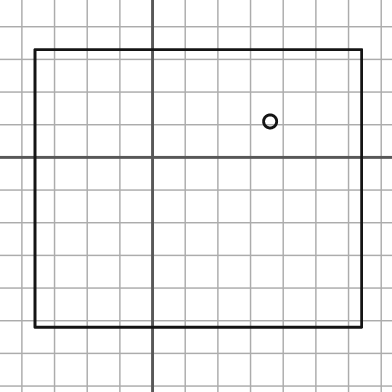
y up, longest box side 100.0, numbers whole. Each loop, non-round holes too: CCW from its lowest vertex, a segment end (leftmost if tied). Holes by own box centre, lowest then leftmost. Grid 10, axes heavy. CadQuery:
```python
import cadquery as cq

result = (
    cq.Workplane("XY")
    .moveTo(-36.0, -52.0)
    .lineTo(64.0, -52.0)
    .lineTo(64.0, 33.0)
    .lineTo(-36.0, 33.0)
    .close()
    .moveTo(36.0, 11.0)
    .circle(2.0)
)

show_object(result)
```